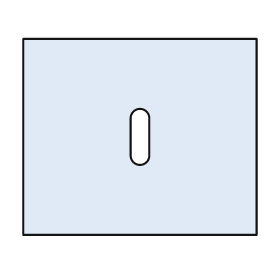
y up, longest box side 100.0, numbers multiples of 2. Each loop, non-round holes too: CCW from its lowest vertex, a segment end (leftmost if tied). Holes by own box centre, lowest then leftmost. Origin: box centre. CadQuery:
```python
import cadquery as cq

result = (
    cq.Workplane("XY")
    .moveTo(-50.0, -42.0)
    .lineTo(50.0, -42.0)
    .lineTo(50.0, 42.0)
    .lineTo(-50.0, 42.0)
    .close()
    .moveTo(-4.0, -8.0)
    .threePointArc((0.0, -12.0), (4.0, -8.0))
    .lineTo(4.0, 8.0)
    .threePointArc((0.0, 12.0), (-4.0, 8.0))
    .close()
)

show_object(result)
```